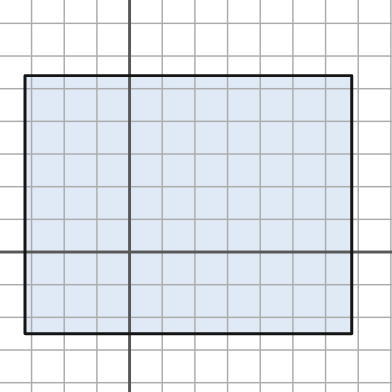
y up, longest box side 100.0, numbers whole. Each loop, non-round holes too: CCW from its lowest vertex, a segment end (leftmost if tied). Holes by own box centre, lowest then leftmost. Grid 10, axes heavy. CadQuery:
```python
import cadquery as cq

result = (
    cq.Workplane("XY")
    .moveTo(-32.0, -25.0)
    .lineTo(68.0, -25.0)
    .lineTo(68.0, 54.0)
    .lineTo(-32.0, 54.0)
    .close()
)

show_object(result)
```